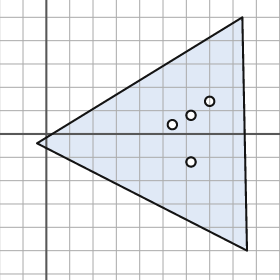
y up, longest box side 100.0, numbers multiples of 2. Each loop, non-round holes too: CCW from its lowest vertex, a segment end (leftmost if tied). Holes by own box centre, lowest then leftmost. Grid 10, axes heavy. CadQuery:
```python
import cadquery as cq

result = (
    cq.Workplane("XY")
    .moveTo(86.0, -50.0)
    .lineTo(84.0, 50.0)
    .lineTo(-4.0, -4.0)
    .close()
    .moveTo(62.0, -12.0)
    .circle(2.0)
    .moveTo(54.0, 4.0)
    .circle(2.0)
    .moveTo(62.0, 8.0)
    .circle(2.0)
    .moveTo(70.0, 14.0)
    .circle(2.0)
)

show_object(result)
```